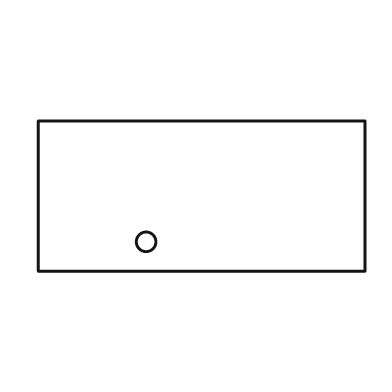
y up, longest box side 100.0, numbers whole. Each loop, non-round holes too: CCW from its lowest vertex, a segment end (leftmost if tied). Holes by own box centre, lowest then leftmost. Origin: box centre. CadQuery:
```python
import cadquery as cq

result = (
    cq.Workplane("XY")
    .moveTo(-50.0, -23.0)
    .lineTo(50.0, -23.0)
    .lineTo(50.0, 23.0)
    .lineTo(-50.0, 23.0)
    .close()
    .moveTo(-17.0, -14.0)
    .circle(3.0)
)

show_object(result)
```